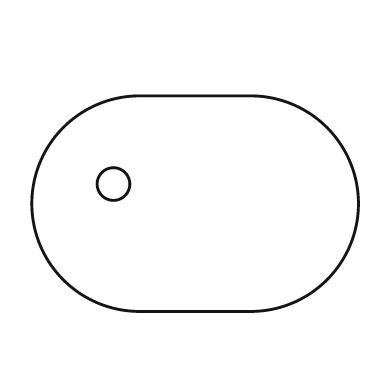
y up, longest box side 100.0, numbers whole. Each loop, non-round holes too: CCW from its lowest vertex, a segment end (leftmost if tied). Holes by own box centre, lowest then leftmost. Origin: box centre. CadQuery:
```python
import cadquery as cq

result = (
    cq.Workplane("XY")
    .moveTo(-17.0, -33.0)
    .lineTo(17.0, -33.0)
    .threePointArc((50.0, 0.0), (17.0, 33.0))
    .lineTo(-17.0, 33.0)
    .threePointArc((-50.0, 0.0), (-17.0, -33.0))
    .close()
    .moveTo(-25.0, 6.0)
    .circle(5.0)
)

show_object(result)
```